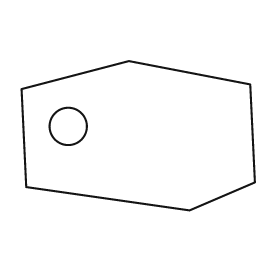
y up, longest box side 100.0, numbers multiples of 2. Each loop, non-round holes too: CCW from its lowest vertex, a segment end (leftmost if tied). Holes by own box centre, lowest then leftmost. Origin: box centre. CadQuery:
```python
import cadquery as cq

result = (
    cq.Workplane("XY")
    .moveTo(22.0, -32.0)
    .lineTo(50.0, -20.0)
    .lineTo(48.0, 22.0)
    .lineTo(-4.0, 32.0)
    .lineTo(-50.0, 20.0)
    .lineTo(-48.0, -22.0)
    .close()
    .moveTo(-30.0, 4.0)
    .circle(8.0)
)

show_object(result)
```